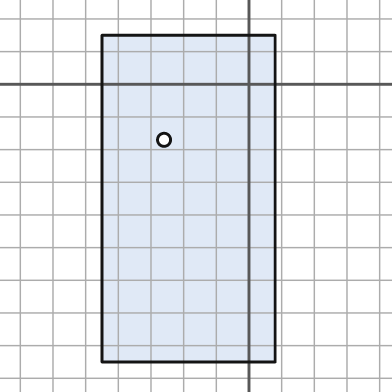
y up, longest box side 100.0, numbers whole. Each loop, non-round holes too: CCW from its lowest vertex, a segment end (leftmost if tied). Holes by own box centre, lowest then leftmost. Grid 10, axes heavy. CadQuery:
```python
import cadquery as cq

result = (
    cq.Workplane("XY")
    .moveTo(-45.0, -85.0)
    .lineTo(8.0, -85.0)
    .lineTo(8.0, 15.0)
    .lineTo(-45.0, 15.0)
    .close()
    .moveTo(-26.0, -17.0)
    .circle(2.0)
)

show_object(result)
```